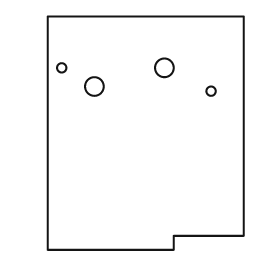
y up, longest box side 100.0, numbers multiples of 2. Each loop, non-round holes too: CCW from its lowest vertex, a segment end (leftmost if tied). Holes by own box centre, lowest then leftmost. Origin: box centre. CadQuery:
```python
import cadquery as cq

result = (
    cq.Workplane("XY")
    .moveTo(-42.0, -50.0)
    .lineTo(12.0, -50.0)
    .lineTo(12.0, -44.0)
    .lineTo(42.0, -44.0)
    .lineTo(42.0, 50.0)
    .lineTo(-42.0, 50.0)
    .close()
    .moveTo(28.0, 18.0)
    .circle(2.0)
    .moveTo(-22.0, 20.0)
    .circle(4.0)
    .moveTo(-36.0, 28.0)
    .circle(2.0)
    .moveTo(8.0, 28.0)
    .circle(4.0)
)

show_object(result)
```